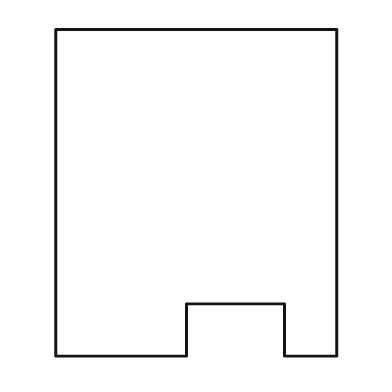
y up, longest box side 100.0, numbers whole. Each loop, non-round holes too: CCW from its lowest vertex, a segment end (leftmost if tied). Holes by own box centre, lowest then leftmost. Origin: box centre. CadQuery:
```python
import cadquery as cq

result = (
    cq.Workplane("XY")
    .moveTo(-43.0, -50.0)
    .lineTo(-3.0, -50.0)
    .lineTo(-3.0, -34.0)
    .lineTo(27.0, -34.0)
    .lineTo(27.0, -50.0)
    .lineTo(43.0, -50.0)
    .lineTo(43.0, 50.0)
    .lineTo(-43.0, 50.0)
    .close()
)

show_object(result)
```